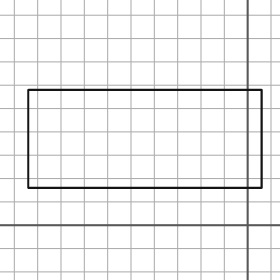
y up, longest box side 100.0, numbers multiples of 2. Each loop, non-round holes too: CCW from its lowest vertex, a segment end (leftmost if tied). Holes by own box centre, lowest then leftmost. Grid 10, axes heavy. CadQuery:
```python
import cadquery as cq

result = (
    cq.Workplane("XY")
    .moveTo(-94.0, 16.0)
    .lineTo(6.0, 16.0)
    .lineTo(6.0, 58.0)
    .lineTo(-94.0, 58.0)
    .close()
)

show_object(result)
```